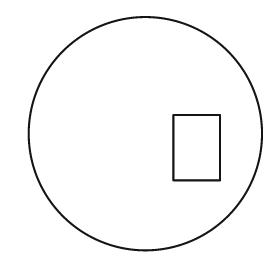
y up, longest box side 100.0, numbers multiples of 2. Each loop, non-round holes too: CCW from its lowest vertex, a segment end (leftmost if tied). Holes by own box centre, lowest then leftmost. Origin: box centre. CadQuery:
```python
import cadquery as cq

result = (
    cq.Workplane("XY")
    .moveTo(0.0, 0.0)
    .circle(50.0)
    .moveTo(12.0, -20.0)
    .lineTo(32.0, -20.0)
    .lineTo(32.0, 8.0)
    .lineTo(12.0, 8.0)
    .close()
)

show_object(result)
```